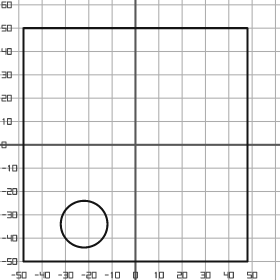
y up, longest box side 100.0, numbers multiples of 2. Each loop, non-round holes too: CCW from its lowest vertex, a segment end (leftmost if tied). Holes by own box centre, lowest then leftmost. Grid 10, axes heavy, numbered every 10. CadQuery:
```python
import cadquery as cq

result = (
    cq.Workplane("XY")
    .moveTo(-48.0, -50.0)
    .lineTo(48.0, -50.0)
    .lineTo(48.0, 50.0)
    .lineTo(-48.0, 50.0)
    .close()
    .moveTo(-22.0, -34.0)
    .circle(10.0)
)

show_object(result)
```